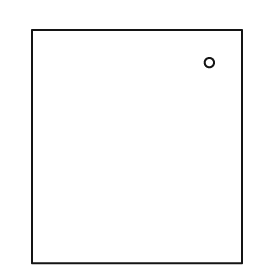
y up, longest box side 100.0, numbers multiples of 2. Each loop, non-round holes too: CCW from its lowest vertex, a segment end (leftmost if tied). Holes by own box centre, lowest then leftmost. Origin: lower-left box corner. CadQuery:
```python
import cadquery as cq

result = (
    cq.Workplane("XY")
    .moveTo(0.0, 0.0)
    .lineTo(90.0, 0.0)
    .lineTo(90.0, 100.0)
    .lineTo(0.0, 100.0)
    .close()
    .moveTo(76.0, 86.0)
    .circle(2.0)
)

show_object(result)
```